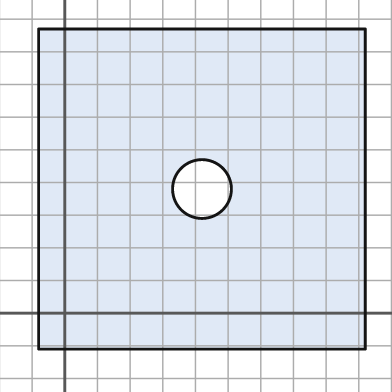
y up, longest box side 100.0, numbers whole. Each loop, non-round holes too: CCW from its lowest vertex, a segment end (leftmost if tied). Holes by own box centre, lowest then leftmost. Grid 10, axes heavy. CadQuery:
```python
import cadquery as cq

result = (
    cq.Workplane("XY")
    .moveTo(-8.0, -11.0)
    .lineTo(92.0, -11.0)
    .lineTo(92.0, 87.0)
    .lineTo(-8.0, 87.0)
    .close()
    .moveTo(42.0, 38.0)
    .circle(9.0)
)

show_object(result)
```